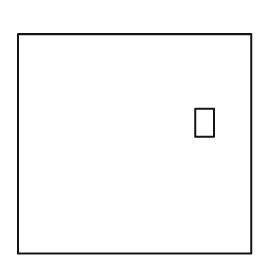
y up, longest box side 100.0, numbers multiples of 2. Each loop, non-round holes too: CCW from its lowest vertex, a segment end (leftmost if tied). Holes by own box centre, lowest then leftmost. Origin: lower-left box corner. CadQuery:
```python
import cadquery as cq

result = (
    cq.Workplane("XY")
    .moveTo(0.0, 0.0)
    .lineTo(100.0, 0.0)
    .lineTo(100.0, 94.0)
    .lineTo(0.0, 94.0)
    .close()
    .moveTo(76.0, 50.0)
    .lineTo(84.0, 50.0)
    .lineTo(84.0, 62.0)
    .lineTo(76.0, 62.0)
    .close()
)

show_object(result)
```